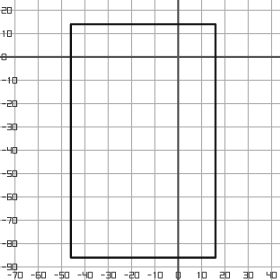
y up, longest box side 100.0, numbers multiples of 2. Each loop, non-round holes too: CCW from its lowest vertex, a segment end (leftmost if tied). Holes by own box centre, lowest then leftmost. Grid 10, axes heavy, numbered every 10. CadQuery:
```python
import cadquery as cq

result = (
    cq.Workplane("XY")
    .moveTo(-46.0, -86.0)
    .lineTo(16.0, -86.0)
    .lineTo(16.0, 14.0)
    .lineTo(-46.0, 14.0)
    .close()
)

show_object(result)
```